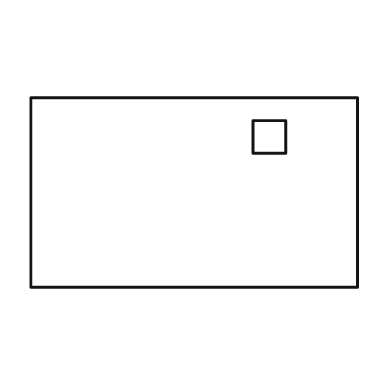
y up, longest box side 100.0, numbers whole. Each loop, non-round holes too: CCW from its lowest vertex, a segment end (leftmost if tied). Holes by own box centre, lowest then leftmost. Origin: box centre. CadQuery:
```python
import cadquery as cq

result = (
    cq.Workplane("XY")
    .moveTo(-50.0, -29.0)
    .lineTo(50.0, -29.0)
    .lineTo(50.0, 29.0)
    .lineTo(-50.0, 29.0)
    .close()
    .moveTo(18.0, 12.0)
    .lineTo(28.0, 12.0)
    .lineTo(28.0, 22.0)
    .lineTo(18.0, 22.0)
    .close()
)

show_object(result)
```